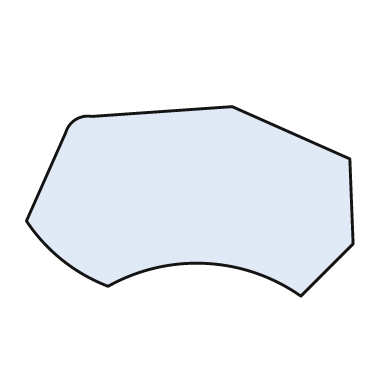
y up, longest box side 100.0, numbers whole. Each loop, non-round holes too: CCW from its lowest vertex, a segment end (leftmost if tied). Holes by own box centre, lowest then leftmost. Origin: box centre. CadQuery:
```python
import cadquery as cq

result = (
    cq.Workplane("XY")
    .moveTo(34.0, -29.0)
    .lineTo(50.0, -13.0)
    .lineTo(49.0, 13.0)
    .lineTo(13.0, 29.0)
    .lineTo(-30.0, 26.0)
    .threePointArc((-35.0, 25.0), (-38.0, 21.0))
    .lineTo(-50.0, -6.0)
    .threePointArc((-39.0, -18.0), (-25.0, -26.0))
    .threePointArc((5.0, -19.0), (34.0, -29.0))
    .close()
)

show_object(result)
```